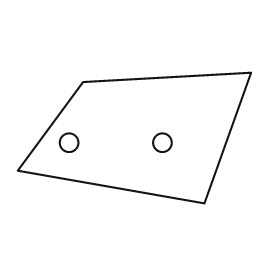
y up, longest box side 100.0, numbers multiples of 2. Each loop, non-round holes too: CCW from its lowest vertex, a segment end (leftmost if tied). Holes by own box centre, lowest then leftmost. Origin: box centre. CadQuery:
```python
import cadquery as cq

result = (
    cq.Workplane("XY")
    .moveTo(30.0, -28.0)
    .lineTo(50.0, 28.0)
    .lineTo(-22.0, 24.0)
    .lineTo(-50.0, -14.0)
    .close()
    .moveTo(-28.0, -2.0)
    .circle(4.0)
    .moveTo(12.0, -2.0)
    .circle(4.0)
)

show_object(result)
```